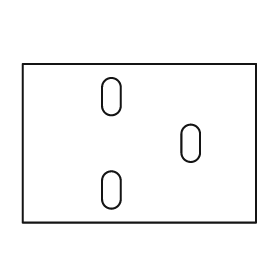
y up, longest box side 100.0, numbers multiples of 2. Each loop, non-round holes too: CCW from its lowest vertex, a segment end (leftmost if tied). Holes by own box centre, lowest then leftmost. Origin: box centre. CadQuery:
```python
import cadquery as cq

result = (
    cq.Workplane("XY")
    .moveTo(-50.0, -34.0)
    .lineTo(50.0, -34.0)
    .lineTo(50.0, 34.0)
    .lineTo(-50.0, 34.0)
    .close()
    .moveTo(-16.0, -24.0)
    .threePointArc((-12.0, -28.0), (-8.0, -24.0))
    .lineTo(-8.0, -16.0)
    .threePointArc((-12.0, -12.0), (-16.0, -16.0))
    .close()
    .moveTo(18.0, -4.0)
    .threePointArc((22.0, -8.0), (26.0, -4.0))
    .lineTo(26.0, 4.0)
    .threePointArc((22.0, 8.0), (18.0, 4.0))
    .close()
    .moveTo(-16.0, 16.0)
    .threePointArc((-12.0, 12.0), (-8.0, 16.0))
    .lineTo(-8.0, 24.0)
    .threePointArc((-12.0, 28.0), (-16.0, 24.0))
    .close()
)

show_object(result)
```